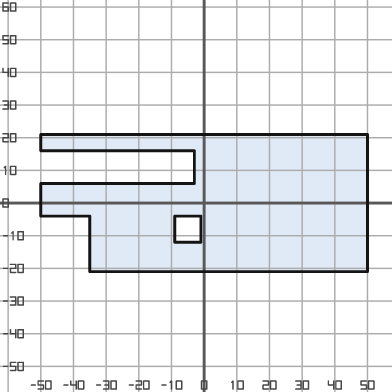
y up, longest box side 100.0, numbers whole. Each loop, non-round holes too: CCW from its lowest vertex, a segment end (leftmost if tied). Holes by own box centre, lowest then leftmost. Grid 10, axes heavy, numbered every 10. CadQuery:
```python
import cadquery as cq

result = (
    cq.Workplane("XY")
    .moveTo(-35.0, -21.0)
    .lineTo(50.0, -21.0)
    .lineTo(50.0, 21.0)
    .lineTo(-50.0, 21.0)
    .lineTo(-50.0, 16.0)
    .lineTo(-3.0, 16.0)
    .lineTo(-3.0, 6.0)
    .lineTo(-50.0, 6.0)
    .lineTo(-50.0, -4.0)
    .lineTo(-35.0, -4.0)
    .close()
    .moveTo(-9.0, -12.0)
    .lineTo(-1.0, -12.0)
    .lineTo(-1.0, -4.0)
    .lineTo(-9.0, -4.0)
    .close()
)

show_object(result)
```